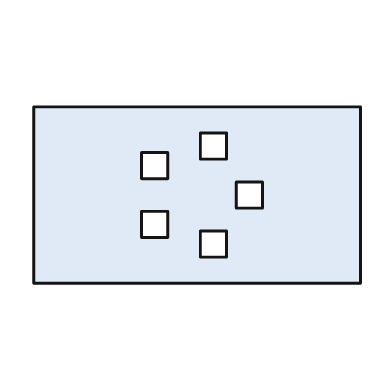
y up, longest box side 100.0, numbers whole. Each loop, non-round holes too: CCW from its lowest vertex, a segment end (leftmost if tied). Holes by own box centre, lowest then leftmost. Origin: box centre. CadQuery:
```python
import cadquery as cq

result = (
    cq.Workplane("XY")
    .moveTo(-50.0, -27.0)
    .lineTo(50.0, -27.0)
    .lineTo(50.0, 27.0)
    .lineTo(-50.0, 27.0)
    .close()
    .moveTo(1.0, -19.0)
    .lineTo(9.0, -19.0)
    .lineTo(9.0, -11.0)
    .lineTo(1.0, -11.0)
    .close()
    .moveTo(-17.0, -13.0)
    .lineTo(-9.0, -13.0)
    .lineTo(-9.0, -5.0)
    .lineTo(-17.0, -5.0)
    .close()
    .moveTo(12.0, -4.0)
    .lineTo(20.0, -4.0)
    .lineTo(20.0, 4.0)
    .lineTo(12.0, 4.0)
    .close()
    .moveTo(-17.0, 5.0)
    .lineTo(-9.0, 5.0)
    .lineTo(-9.0, 13.0)
    .lineTo(-17.0, 13.0)
    .close()
    .moveTo(1.0, 11.0)
    .lineTo(9.0, 11.0)
    .lineTo(9.0, 19.0)
    .lineTo(1.0, 19.0)
    .close()
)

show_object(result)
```